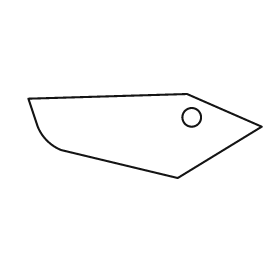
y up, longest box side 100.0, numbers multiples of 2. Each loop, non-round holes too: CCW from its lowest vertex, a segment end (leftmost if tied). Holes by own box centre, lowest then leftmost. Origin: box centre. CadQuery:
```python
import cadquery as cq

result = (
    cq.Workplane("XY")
    .moveTo(14.0, -18.0)
    .lineTo(50.0, 4.0)
    .lineTo(18.0, 18.0)
    .lineTo(-50.0, 16.0)
    .lineTo(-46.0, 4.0)
    .threePointArc((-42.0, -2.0), (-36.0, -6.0))
    .close()
    .moveTo(20.0, 8.0)
    .circle(4.0)
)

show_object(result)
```